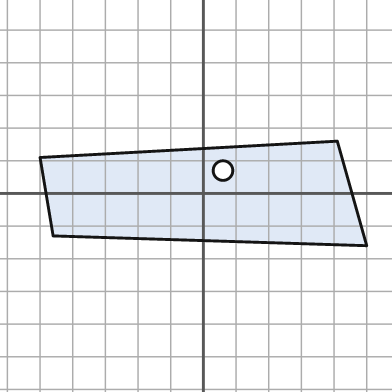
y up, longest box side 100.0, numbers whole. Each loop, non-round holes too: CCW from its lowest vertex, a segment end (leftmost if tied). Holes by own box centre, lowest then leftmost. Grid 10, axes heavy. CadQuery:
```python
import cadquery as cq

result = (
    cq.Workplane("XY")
    .moveTo(50.0, -16.0)
    .lineTo(41.0, 16.0)
    .lineTo(-50.0, 11.0)
    .lineTo(-46.0, -13.0)
    .close()
    .moveTo(6.0, 7.0)
    .circle(3.0)
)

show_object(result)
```